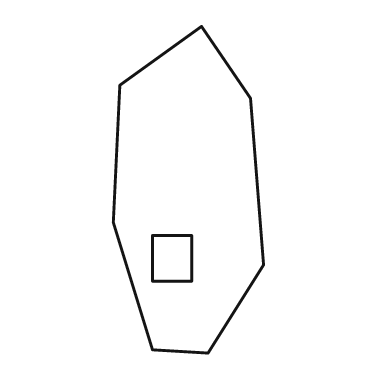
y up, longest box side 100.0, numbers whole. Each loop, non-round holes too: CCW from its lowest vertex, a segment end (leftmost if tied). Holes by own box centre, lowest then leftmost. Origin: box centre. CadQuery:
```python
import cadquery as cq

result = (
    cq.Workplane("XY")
    .moveTo(6.0, -50.0)
    .lineTo(23.0, -23.0)
    .lineTo(19.0, 28.0)
    .lineTo(4.0, 50.0)
    .lineTo(-21.0, 32.0)
    .lineTo(-23.0, -10.0)
    .lineTo(-11.0, -49.0)
    .close()
    .moveTo(-11.0, -28.0)
    .lineTo(1.0, -28.0)
    .lineTo(1.0, -14.0)
    .lineTo(-11.0, -14.0)
    .close()
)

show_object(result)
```